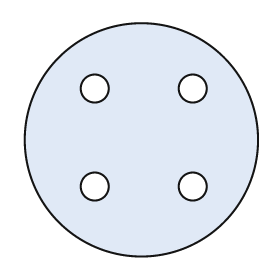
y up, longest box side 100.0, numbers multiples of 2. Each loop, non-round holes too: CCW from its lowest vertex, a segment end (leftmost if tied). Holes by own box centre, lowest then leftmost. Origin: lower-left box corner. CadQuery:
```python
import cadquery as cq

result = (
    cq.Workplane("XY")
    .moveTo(50.0, 50.0)
    .circle(50.0)
    .moveTo(30.0, 30.0)
    .circle(6.0)
    .moveTo(72.0, 30.0)
    .circle(6.0)
    .moveTo(30.0, 72.0)
    .circle(6.0)
    .moveTo(72.0, 72.0)
    .circle(6.0)
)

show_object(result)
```